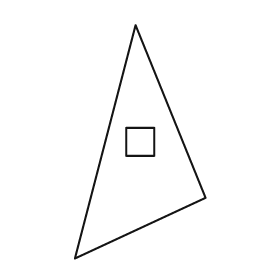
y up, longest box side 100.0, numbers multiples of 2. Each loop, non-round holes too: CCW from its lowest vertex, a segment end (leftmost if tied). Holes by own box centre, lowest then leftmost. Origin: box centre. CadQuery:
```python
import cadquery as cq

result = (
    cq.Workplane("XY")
    .moveTo(-28.0, -50.0)
    .lineTo(28.0, -24.0)
    .lineTo(-2.0, 50.0)
    .close()
    .moveTo(-6.0, -6.0)
    .lineTo(6.0, -6.0)
    .lineTo(6.0, 6.0)
    .lineTo(-6.0, 6.0)
    .close()
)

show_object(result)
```